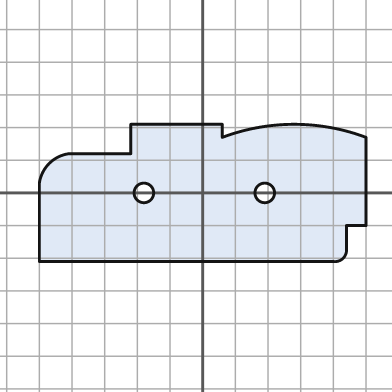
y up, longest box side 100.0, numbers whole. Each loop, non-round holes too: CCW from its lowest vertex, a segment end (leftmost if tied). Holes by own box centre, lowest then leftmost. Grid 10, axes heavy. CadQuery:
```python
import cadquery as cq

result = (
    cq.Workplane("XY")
    .moveTo(-50.0, -21.0)
    .lineTo(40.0, -21.0)
    .threePointArc((43.0, -20.0), (44.0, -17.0))
    .lineTo(44.0, -10.0)
    .lineTo(50.0, -10.0)
    .lineTo(50.0, 17.0)
    .threePointArc((28.0, 21.0), (6.0, 17.0))
    .lineTo(6.0, 21.0)
    .lineTo(-22.0, 21.0)
    .lineTo(-22.0, 12.0)
    .lineTo(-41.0, 12.0)
    .threePointArc((-47.0, 9.0), (-50.0, 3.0))
    .close()
    .moveTo(-18.0, 0.0)
    .circle(3.0)
    .moveTo(19.0, 0.0)
    .circle(3.0)
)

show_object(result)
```